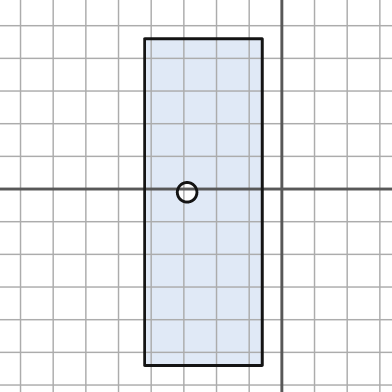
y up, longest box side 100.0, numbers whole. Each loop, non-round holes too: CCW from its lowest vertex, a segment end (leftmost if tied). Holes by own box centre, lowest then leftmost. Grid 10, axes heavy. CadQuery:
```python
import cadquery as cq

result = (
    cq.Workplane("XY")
    .moveTo(-42.0, -54.0)
    .lineTo(-6.0, -54.0)
    .lineTo(-6.0, 46.0)
    .lineTo(-42.0, 46.0)
    .close()
    .moveTo(-29.0, -1.0)
    .circle(3.0)
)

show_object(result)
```